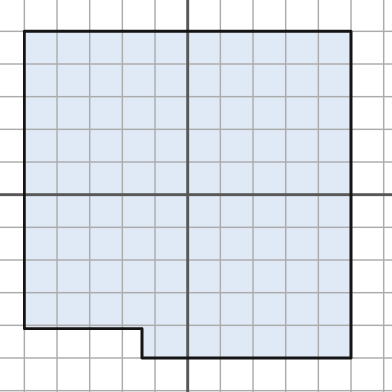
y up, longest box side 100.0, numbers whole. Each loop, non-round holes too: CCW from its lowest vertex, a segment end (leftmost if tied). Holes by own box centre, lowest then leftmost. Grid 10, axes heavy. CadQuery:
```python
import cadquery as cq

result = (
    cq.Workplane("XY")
    .moveTo(-14.0, -50.0)
    .lineTo(50.0, -50.0)
    .lineTo(50.0, 50.0)
    .lineTo(-50.0, 50.0)
    .lineTo(-50.0, -41.0)
    .lineTo(-14.0, -41.0)
    .close()
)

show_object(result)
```